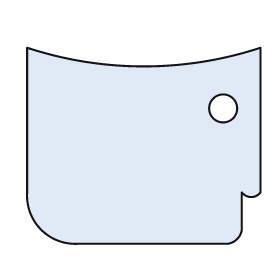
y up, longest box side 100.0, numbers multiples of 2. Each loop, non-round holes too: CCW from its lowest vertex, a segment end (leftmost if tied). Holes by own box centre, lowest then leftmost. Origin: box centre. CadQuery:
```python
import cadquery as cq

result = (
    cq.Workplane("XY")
    .moveTo(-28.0, -42.0)
    .lineTo(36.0, -42.0)
    .threePointArc((40.0, -40.0), (42.0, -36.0))
    .lineTo(42.0, -20.0)
    .threePointArc((46.0, -22.0), (50.0, -20.0))
    .lineTo(50.0, 42.0)
    .threePointArc((0.0, 34.0), (-50.0, 42.0))
    .lineTo(-50.0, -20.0)
    .threePointArc((-44.0, -36.0), (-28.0, -42.0))
    .close()
    .moveTo(34.0, 16.0)
    .circle(6.0)
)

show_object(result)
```